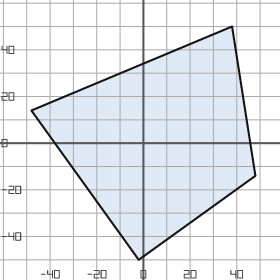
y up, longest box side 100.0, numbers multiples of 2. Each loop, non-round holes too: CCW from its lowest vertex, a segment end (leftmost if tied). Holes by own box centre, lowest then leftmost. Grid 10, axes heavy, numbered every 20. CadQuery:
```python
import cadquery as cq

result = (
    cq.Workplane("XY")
    .moveTo(-2.0, -50.0)
    .lineTo(48.0, -14.0)
    .lineTo(38.0, 50.0)
    .lineTo(-48.0, 14.0)
    .close()
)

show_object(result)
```